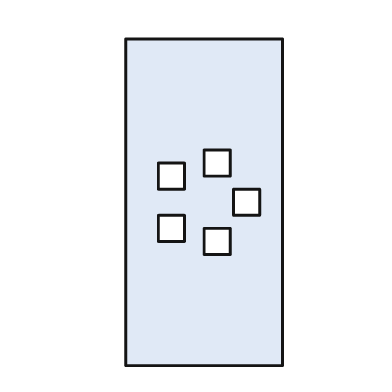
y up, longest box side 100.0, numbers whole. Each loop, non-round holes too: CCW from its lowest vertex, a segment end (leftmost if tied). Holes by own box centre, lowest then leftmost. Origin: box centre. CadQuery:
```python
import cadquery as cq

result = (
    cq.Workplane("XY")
    .moveTo(-24.0, -50.0)
    .lineTo(24.0, -50.0)
    .lineTo(24.0, 50.0)
    .lineTo(-24.0, 50.0)
    .close()
    .moveTo(0.0, -16.0)
    .lineTo(8.0, -16.0)
    .lineTo(8.0, -8.0)
    .lineTo(0.0, -8.0)
    .close()
    .moveTo(-14.0, -12.0)
    .lineTo(-6.0, -12.0)
    .lineTo(-6.0, -4.0)
    .lineTo(-14.0, -4.0)
    .close()
    .moveTo(9.0, -4.0)
    .lineTo(17.0, -4.0)
    .lineTo(17.0, 4.0)
    .lineTo(9.0, 4.0)
    .close()
    .moveTo(-14.0, 4.0)
    .lineTo(-6.0, 4.0)
    .lineTo(-6.0, 12.0)
    .lineTo(-14.0, 12.0)
    .close()
    .moveTo(0.0, 8.0)
    .lineTo(8.0, 8.0)
    .lineTo(8.0, 16.0)
    .lineTo(0.0, 16.0)
    .close()
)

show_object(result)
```